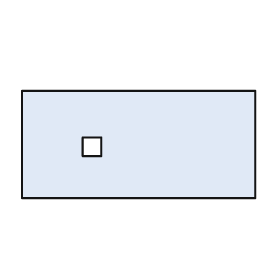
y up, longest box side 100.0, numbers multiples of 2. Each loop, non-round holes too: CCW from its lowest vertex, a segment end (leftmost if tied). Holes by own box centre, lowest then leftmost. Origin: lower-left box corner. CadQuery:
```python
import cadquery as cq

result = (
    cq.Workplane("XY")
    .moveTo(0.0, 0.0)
    .lineTo(100.0, 0.0)
    .lineTo(100.0, 46.0)
    .lineTo(0.0, 46.0)
    .close()
    .moveTo(26.0, 18.0)
    .lineTo(34.0, 18.0)
    .lineTo(34.0, 26.0)
    .lineTo(26.0, 26.0)
    .close()
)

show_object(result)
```